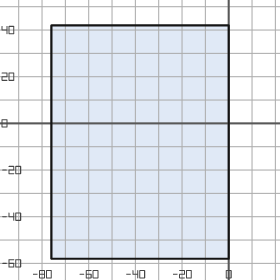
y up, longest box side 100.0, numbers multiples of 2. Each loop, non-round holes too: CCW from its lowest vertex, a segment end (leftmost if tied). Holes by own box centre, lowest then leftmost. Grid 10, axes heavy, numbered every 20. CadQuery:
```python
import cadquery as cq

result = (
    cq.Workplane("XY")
    .moveTo(-76.0, -58.0)
    .lineTo(0.0, -58.0)
    .lineTo(0.0, 42.0)
    .lineTo(-76.0, 42.0)
    .close()
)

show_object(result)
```